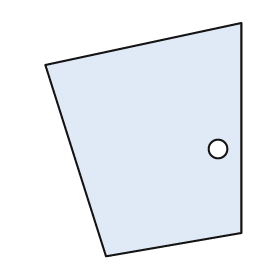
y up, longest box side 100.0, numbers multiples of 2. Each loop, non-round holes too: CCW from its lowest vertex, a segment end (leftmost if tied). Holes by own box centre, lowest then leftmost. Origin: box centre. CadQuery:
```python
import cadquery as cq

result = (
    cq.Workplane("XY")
    .moveTo(-16.0, -50.0)
    .lineTo(42.0, -40.0)
    .lineTo(42.0, 50.0)
    .lineTo(-42.0, 32.0)
    .close()
    .moveTo(32.0, -4.0)
    .circle(4.0)
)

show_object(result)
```